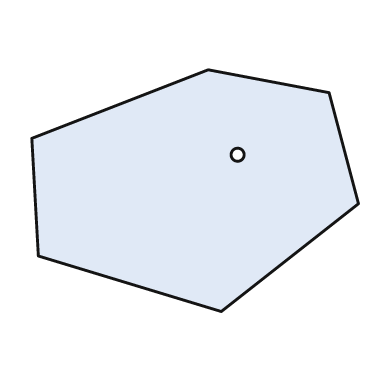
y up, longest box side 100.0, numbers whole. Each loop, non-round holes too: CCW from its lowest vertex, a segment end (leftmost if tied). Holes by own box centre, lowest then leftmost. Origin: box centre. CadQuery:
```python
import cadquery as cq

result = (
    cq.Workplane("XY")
    .moveTo(8.0, -37.0)
    .lineTo(50.0, -4.0)
    .lineTo(41.0, 30.0)
    .lineTo(4.0, 37.0)
    .lineTo(-50.0, 16.0)
    .lineTo(-48.0, -20.0)
    .close()
    .moveTo(13.0, 11.0)
    .circle(2.0)
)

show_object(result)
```